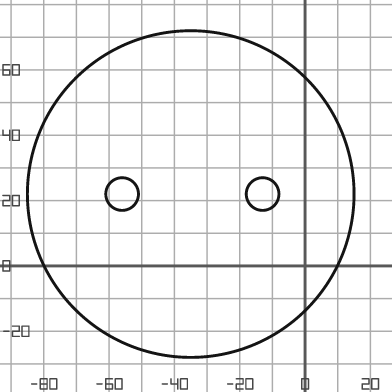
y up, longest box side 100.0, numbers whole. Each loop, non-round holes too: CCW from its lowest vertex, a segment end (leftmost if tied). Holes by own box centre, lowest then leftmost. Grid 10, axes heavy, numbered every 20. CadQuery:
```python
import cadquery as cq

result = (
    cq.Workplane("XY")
    .moveTo(-35.0, 22.0)
    .circle(50.0)
    .moveTo(-56.0, 22.0)
    .circle(5.0)
    .moveTo(-13.0, 22.0)
    .circle(5.0)
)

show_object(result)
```